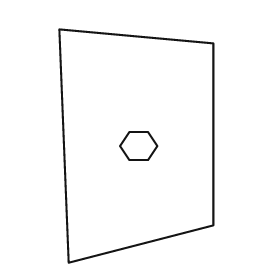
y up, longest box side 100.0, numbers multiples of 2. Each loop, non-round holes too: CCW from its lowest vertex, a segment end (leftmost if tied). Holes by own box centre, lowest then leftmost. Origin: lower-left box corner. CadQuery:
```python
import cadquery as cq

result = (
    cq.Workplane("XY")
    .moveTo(4.0, 0.0)
    .lineTo(66.0, 16.0)
    .lineTo(66.0, 94.0)
    .lineTo(0.0, 100.0)
    .close()
    .moveTo(30.0, 44.0)
    .lineTo(38.0, 44.0)
    .lineTo(42.0, 50.0)
    .lineTo(38.0, 56.0)
    .lineTo(30.0, 56.0)
    .lineTo(26.0, 50.0)
    .close()
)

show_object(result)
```